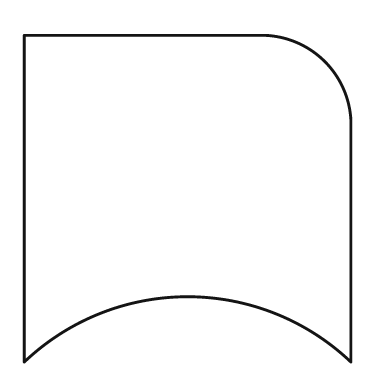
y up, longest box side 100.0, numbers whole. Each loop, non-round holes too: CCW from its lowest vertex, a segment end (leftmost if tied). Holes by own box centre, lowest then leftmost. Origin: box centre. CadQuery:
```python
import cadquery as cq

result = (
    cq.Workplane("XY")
    .moveTo(-50.0, -50.0)
    .threePointArc((0.0, -30.0), (50.0, -50.0))
    .lineTo(50.0, 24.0)
    .threePointArc((42.0, 42.0), (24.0, 50.0))
    .lineTo(-50.0, 50.0)
    .close()
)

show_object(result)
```